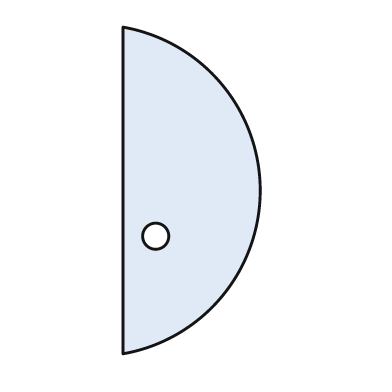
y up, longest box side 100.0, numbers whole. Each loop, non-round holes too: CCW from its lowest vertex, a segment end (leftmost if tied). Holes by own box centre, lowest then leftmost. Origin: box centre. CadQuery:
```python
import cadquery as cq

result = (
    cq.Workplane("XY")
    .moveTo(-21.0, -50.0)
    .threePointArc((21.0, 0.0), (-21.0, 50.0))
    .close()
    .moveTo(-11.0, -14.0)
    .circle(4.0)
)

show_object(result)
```